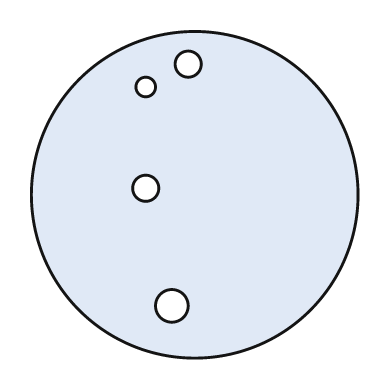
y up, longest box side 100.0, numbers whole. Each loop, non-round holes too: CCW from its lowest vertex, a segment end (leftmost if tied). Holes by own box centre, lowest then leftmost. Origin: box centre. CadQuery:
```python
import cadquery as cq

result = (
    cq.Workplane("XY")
    .moveTo(0.0, 0.0)
    .circle(50.0)
    .moveTo(-7.0, -34.0)
    .circle(5.0)
    .moveTo(-15.0, 2.0)
    .circle(4.0)
    .moveTo(-15.0, 33.0)
    .circle(3.0)
    .moveTo(-2.0, 40.0)
    .circle(4.0)
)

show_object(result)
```